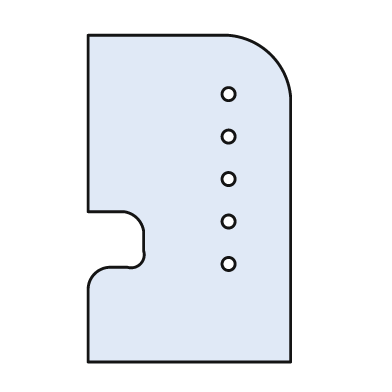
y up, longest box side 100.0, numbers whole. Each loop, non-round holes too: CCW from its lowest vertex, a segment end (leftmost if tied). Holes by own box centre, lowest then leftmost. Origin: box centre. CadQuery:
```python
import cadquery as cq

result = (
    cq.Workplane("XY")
    .moveTo(-31.0, -50.0)
    .lineTo(31.0, -50.0)
    .lineTo(31.0, 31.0)
    .threePointArc((25.0, 44.0), (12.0, 50.0))
    .lineTo(-31.0, 50.0)
    .lineTo(-31.0, -4.0)
    .lineTo(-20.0, -4.0)
    .threePointArc((-16.0, -6.0), (-14.0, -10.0))
    .lineTo(-14.0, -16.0)
    .threePointArc((-15.0, -20.0), (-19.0, -21.0))
    .lineTo(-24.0, -21.0)
    .threePointArc((-29.0, -23.0), (-31.0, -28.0))
    .close()
    .moveTo(12.0, -20.0)
    .circle(2.0)
    .moveTo(12.0, -7.0)
    .circle(2.0)
    .moveTo(12.0, 6.0)
    .circle(2.0)
    .moveTo(12.0, 19.0)
    .circle(2.0)
    .moveTo(12.0, 32.0)
    .circle(2.0)
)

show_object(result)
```